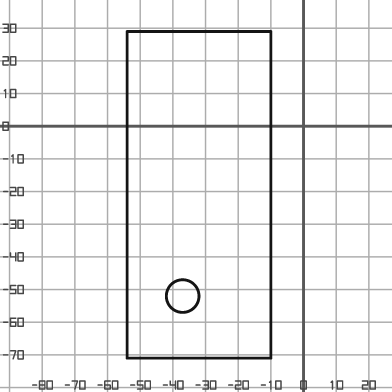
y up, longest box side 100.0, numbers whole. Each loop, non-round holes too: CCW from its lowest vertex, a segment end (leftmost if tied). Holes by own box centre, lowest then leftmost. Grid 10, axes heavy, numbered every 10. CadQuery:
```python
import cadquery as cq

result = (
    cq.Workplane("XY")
    .moveTo(-54.0, -71.0)
    .lineTo(-10.0, -71.0)
    .lineTo(-10.0, 29.0)
    .lineTo(-54.0, 29.0)
    .close()
    .moveTo(-37.0, -52.0)
    .circle(5.0)
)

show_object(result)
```